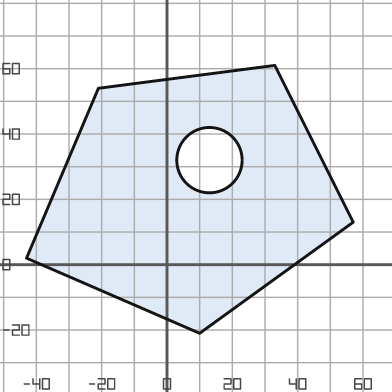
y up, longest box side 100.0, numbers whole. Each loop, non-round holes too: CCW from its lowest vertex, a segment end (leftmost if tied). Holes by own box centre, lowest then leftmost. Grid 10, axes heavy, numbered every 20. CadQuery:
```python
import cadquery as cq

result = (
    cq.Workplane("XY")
    .moveTo(10.0, -21.0)
    .lineTo(57.0, 13.0)
    .lineTo(33.0, 61.0)
    .lineTo(-21.0, 54.0)
    .lineTo(-43.0, 2.0)
    .close()
    .moveTo(13.0, 32.0)
    .circle(10.0)
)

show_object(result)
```